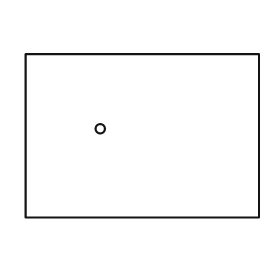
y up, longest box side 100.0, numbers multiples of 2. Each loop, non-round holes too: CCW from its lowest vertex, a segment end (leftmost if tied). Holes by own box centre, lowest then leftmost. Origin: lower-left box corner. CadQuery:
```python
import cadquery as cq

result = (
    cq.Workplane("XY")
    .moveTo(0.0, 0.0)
    .lineTo(100.0, 0.0)
    .lineTo(100.0, 70.0)
    .lineTo(0.0, 70.0)
    .close()
    .moveTo(32.0, 38.0)
    .circle(2.0)
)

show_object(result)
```